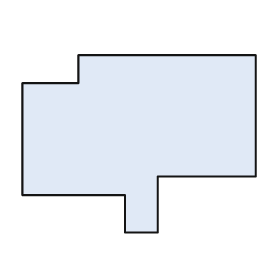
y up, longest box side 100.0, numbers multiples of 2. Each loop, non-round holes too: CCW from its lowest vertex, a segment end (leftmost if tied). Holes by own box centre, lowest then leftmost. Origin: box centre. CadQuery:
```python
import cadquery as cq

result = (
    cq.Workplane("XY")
    .moveTo(-6.0, -38.0)
    .lineTo(8.0, -38.0)
    .lineTo(8.0, -14.0)
    .lineTo(50.0, -14.0)
    .lineTo(50.0, 38.0)
    .lineTo(-26.0, 38.0)
    .lineTo(-26.0, 26.0)
    .lineTo(-50.0, 26.0)
    .lineTo(-50.0, -22.0)
    .lineTo(-6.0, -22.0)
    .close()
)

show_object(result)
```